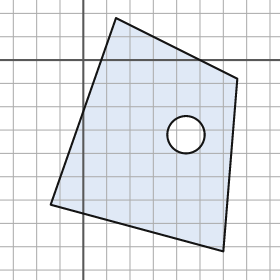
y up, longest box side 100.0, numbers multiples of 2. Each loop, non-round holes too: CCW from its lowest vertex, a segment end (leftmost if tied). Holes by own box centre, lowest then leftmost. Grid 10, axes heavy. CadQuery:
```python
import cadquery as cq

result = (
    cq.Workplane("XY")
    .moveTo(60.0, -82.0)
    .lineTo(66.0, -8.0)
    .lineTo(14.0, 18.0)
    .lineTo(-14.0, -62.0)
    .close()
    .moveTo(44.0, -32.0)
    .circle(8.0)
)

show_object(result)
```